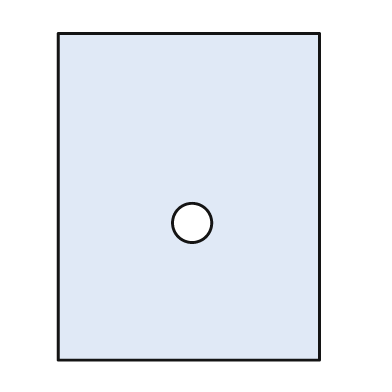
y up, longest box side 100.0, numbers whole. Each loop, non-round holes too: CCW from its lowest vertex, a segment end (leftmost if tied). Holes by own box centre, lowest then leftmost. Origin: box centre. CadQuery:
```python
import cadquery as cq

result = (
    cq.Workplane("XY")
    .moveTo(-40.0, -50.0)
    .lineTo(40.0, -50.0)
    .lineTo(40.0, 50.0)
    .lineTo(-40.0, 50.0)
    .close()
    .moveTo(1.0, -8.0)
    .circle(6.0)
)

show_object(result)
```